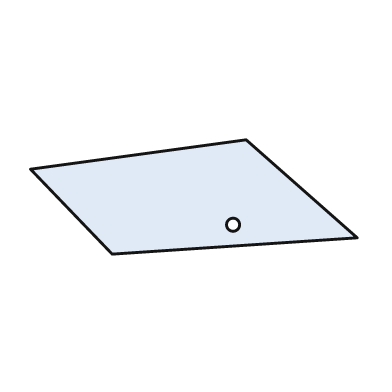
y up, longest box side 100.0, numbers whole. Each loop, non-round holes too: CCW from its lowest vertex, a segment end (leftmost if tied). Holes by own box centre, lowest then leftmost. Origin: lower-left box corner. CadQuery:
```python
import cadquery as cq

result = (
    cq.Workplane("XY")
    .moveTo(25.0, 0.0)
    .lineTo(100.0, 5.0)
    .lineTo(66.0, 35.0)
    .lineTo(0.0, 26.0)
    .close()
    .moveTo(62.0, 9.0)
    .circle(2.0)
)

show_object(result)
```